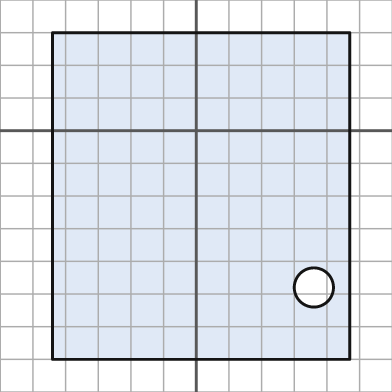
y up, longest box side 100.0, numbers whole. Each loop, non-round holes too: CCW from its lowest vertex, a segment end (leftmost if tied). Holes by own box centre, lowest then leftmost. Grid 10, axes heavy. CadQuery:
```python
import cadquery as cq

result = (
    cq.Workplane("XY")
    .moveTo(-44.0, -70.0)
    .lineTo(47.0, -70.0)
    .lineTo(47.0, 30.0)
    .lineTo(-44.0, 30.0)
    .close()
    .moveTo(36.0, -48.0)
    .circle(6.0)
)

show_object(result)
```